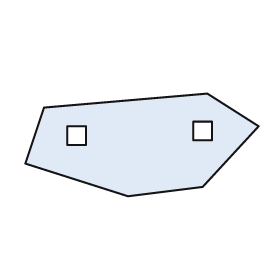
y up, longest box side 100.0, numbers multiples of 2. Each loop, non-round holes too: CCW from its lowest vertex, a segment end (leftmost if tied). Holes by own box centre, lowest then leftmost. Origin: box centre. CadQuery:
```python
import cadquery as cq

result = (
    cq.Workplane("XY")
    .moveTo(-6.0, -22.0)
    .lineTo(26.0, -18.0)
    .lineTo(50.0, 8.0)
    .lineTo(28.0, 22.0)
    .lineTo(-42.0, 16.0)
    .lineTo(-50.0, -8.0)
    .close()
    .moveTo(-32.0, 0.0)
    .lineTo(-24.0, 0.0)
    .lineTo(-24.0, 8.0)
    .lineTo(-32.0, 8.0)
    .close()
    .moveTo(22.0, 2.0)
    .lineTo(30.0, 2.0)
    .lineTo(30.0, 10.0)
    .lineTo(22.0, 10.0)
    .close()
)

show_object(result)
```